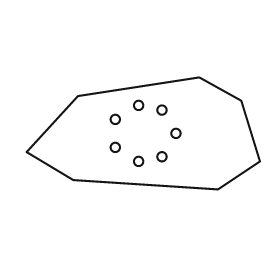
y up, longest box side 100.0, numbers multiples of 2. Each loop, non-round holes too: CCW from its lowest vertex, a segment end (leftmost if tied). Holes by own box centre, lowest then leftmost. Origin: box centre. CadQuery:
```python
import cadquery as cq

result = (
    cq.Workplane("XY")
    .moveTo(32.0, -24.0)
    .lineTo(50.0, -12.0)
    .lineTo(42.0, 14.0)
    .lineTo(24.0, 24.0)
    .lineTo(-28.0, 16.0)
    .lineTo(-50.0, -8.0)
    .lineTo(-30.0, -20.0)
    .close()
    .moveTo(-2.0, -12.0)
    .circle(2.0)
    .moveTo(8.0, -10.0)
    .circle(2.0)
    .moveTo(-12.0, -6.0)
    .circle(2.0)
    .moveTo(14.0, 0.0)
    .circle(2.0)
    .moveTo(-12.0, 6.0)
    .circle(2.0)
    .moveTo(8.0, 10.0)
    .circle(2.0)
    .moveTo(-2.0, 12.0)
    .circle(2.0)
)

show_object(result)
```